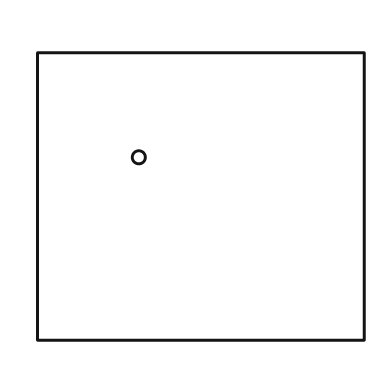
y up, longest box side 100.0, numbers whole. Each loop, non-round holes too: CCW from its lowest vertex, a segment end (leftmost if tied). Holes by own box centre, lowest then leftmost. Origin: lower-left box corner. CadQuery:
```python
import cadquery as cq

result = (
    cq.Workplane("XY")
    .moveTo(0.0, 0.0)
    .lineTo(100.0, 0.0)
    .lineTo(100.0, 88.0)
    .lineTo(0.0, 88.0)
    .close()
    .moveTo(31.0, 56.0)
    .circle(2.0)
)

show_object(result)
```